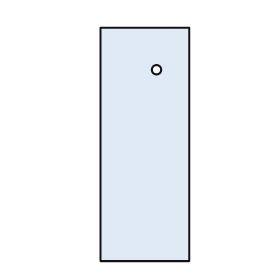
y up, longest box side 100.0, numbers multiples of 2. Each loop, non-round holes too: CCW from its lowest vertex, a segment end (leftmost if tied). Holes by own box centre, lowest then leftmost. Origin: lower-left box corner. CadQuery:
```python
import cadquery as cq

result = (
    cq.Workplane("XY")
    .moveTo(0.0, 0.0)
    .lineTo(38.0, 0.0)
    .lineTo(38.0, 100.0)
    .lineTo(0.0, 100.0)
    .close()
    .moveTo(24.0, 82.0)
    .circle(2.0)
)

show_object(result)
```